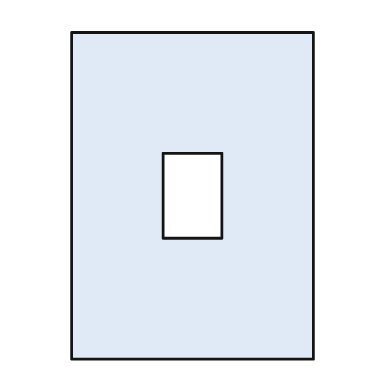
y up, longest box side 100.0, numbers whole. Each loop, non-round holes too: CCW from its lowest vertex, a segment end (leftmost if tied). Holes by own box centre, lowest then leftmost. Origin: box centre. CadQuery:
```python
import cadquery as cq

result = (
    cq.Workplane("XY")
    .moveTo(-37.0, -50.0)
    .lineTo(37.0, -50.0)
    .lineTo(37.0, 50.0)
    .lineTo(-37.0, 50.0)
    .close()
    .moveTo(-9.0, -13.0)
    .lineTo(9.0, -13.0)
    .lineTo(9.0, 13.0)
    .lineTo(-9.0, 13.0)
    .close()
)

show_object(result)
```